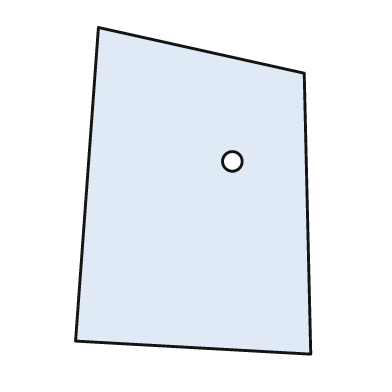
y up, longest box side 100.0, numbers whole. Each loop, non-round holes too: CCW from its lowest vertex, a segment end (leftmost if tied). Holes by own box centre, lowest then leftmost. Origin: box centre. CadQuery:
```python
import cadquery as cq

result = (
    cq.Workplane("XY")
    .moveTo(36.0, -50.0)
    .lineTo(34.0, 36.0)
    .lineTo(-29.0, 50.0)
    .lineTo(-36.0, -46.0)
    .close()
    .moveTo(12.0, 9.0)
    .circle(3.0)
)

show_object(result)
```